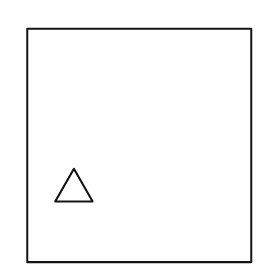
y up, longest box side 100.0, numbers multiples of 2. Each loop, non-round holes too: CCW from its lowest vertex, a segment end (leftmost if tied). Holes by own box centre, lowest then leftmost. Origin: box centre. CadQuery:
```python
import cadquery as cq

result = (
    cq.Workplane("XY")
    .moveTo(-48.0, -50.0)
    .lineTo(48.0, -50.0)
    .lineTo(48.0, 50.0)
    .lineTo(-48.0, 50.0)
    .close()
    .moveTo(-36.0, -24.0)
    .lineTo(-20.0, -24.0)
    .lineTo(-28.0, -10.0)
    .close()
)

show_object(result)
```